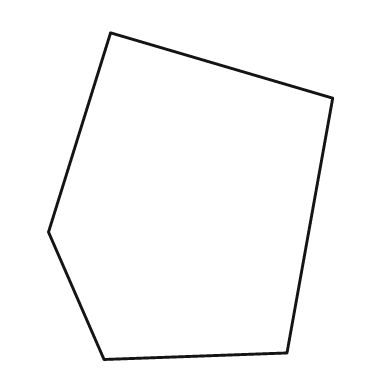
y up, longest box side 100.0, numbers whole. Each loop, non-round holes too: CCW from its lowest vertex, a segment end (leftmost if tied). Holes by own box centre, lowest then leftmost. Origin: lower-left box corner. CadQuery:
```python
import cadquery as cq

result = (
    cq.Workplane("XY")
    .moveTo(17.0, 0.0)
    .lineTo(73.0, 2.0)
    .lineTo(87.0, 80.0)
    .lineTo(19.0, 100.0)
    .lineTo(0.0, 39.0)
    .close()
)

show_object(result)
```